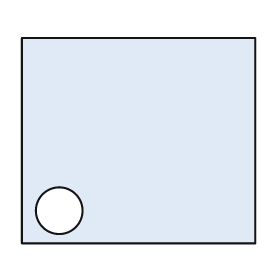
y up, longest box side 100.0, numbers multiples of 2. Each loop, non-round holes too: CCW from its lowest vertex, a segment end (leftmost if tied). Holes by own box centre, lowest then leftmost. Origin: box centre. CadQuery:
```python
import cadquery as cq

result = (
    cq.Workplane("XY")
    .moveTo(-50.0, -44.0)
    .lineTo(50.0, -44.0)
    .lineTo(50.0, 44.0)
    .lineTo(-50.0, 44.0)
    .close()
    .moveTo(-34.0, -30.0)
    .circle(10.0)
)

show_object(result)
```